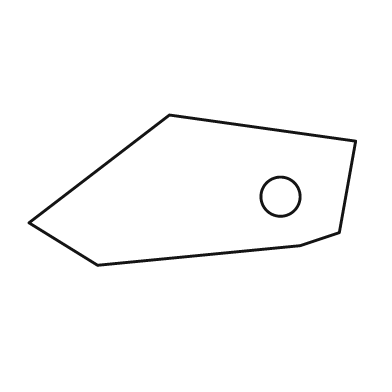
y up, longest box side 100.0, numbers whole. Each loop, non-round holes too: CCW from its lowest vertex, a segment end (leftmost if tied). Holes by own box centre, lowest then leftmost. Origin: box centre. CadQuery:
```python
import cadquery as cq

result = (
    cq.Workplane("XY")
    .moveTo(-29.0, -23.0)
    .lineTo(33.0, -17.0)
    .lineTo(45.0, -13.0)
    .lineTo(50.0, 15.0)
    .lineTo(-7.0, 23.0)
    .lineTo(-50.0, -10.0)
    .close()
    .moveTo(27.0, -2.0)
    .circle(6.0)
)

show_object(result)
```